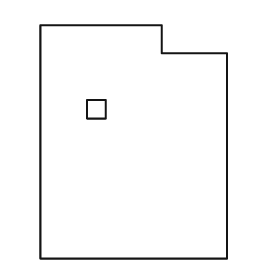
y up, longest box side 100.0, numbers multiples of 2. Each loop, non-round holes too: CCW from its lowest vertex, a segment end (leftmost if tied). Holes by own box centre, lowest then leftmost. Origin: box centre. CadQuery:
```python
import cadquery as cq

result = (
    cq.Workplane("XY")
    .moveTo(-40.0, -50.0)
    .lineTo(40.0, -50.0)
    .lineTo(40.0, 38.0)
    .lineTo(12.0, 38.0)
    .lineTo(12.0, 50.0)
    .lineTo(-40.0, 50.0)
    .close()
    .moveTo(-20.0, 10.0)
    .lineTo(-12.0, 10.0)
    .lineTo(-12.0, 18.0)
    .lineTo(-20.0, 18.0)
    .close()
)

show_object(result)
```